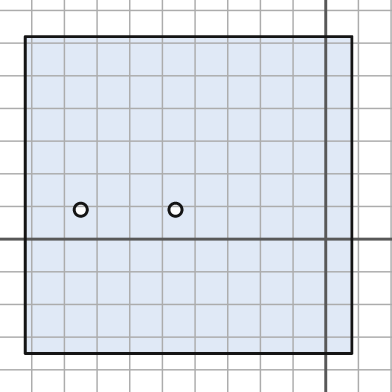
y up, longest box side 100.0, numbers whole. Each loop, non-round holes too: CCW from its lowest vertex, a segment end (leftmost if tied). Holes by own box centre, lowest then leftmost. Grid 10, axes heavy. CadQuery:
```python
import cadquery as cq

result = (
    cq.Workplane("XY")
    .moveTo(-92.0, -35.0)
    .lineTo(8.0, -35.0)
    .lineTo(8.0, 62.0)
    .lineTo(-92.0, 62.0)
    .close()
    .moveTo(-75.0, 9.0)
    .circle(2.0)
    .moveTo(-46.0, 9.0)
    .circle(2.0)
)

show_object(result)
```